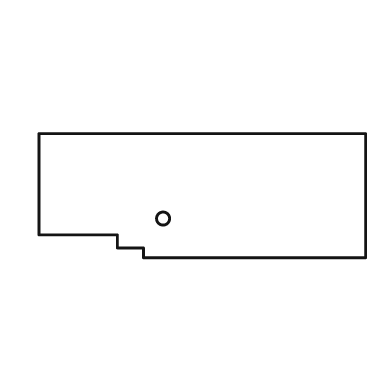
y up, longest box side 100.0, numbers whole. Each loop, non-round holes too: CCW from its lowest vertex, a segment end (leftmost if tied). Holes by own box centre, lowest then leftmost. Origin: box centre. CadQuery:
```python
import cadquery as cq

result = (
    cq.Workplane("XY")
    .moveTo(-18.0, -19.0)
    .lineTo(50.0, -19.0)
    .lineTo(50.0, 19.0)
    .lineTo(-50.0, 19.0)
    .lineTo(-50.0, -12.0)
    .lineTo(-26.0, -12.0)
    .lineTo(-26.0, -16.0)
    .lineTo(-18.0, -16.0)
    .close()
    .moveTo(-12.0, -7.0)
    .circle(2.0)
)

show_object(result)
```